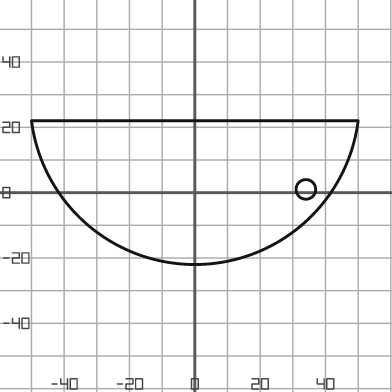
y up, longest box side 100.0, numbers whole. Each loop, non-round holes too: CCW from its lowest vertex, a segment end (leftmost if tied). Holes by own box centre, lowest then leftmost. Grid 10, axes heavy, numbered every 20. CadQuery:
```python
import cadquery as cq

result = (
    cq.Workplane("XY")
    .moveTo(-50.0, 22.0)
    .threePointArc((0.0, -22.0), (50.0, 22.0))
    .close()
    .moveTo(34.0, 1.0)
    .circle(3.0)
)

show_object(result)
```